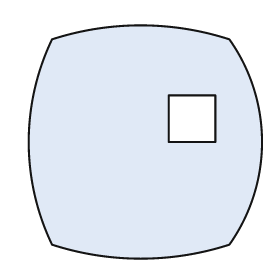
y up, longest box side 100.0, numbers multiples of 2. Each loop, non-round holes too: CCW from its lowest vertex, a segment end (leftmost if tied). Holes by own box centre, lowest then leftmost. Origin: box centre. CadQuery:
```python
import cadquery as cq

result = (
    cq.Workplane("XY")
    .moveTo(-40.0, -44.0)
    .threePointArc((-2.0, -50.0), (36.0, -44.0))
    .threePointArc((50.0, 0.0), (36.0, 44.0))
    .threePointArc((-2.0, 50.0), (-40.0, 44.0))
    .threePointArc((-50.0, 0.0), (-40.0, -44.0))
    .close()
    .moveTo(10.0, 0.0)
    .lineTo(30.0, 0.0)
    .lineTo(30.0, 20.0)
    .lineTo(10.0, 20.0)
    .close()
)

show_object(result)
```